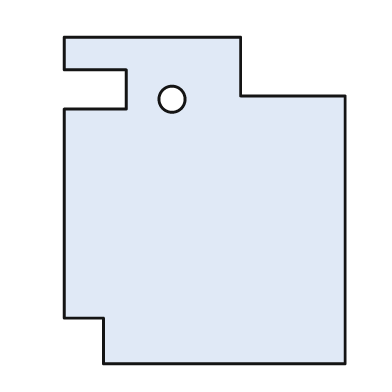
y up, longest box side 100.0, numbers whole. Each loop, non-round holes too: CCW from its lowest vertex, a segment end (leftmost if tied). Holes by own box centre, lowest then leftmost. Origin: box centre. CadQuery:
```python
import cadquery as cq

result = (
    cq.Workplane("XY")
    .moveTo(-31.0, -50.0)
    .lineTo(43.0, -50.0)
    .lineTo(43.0, 32.0)
    .lineTo(11.0, 32.0)
    .lineTo(11.0, 50.0)
    .lineTo(-43.0, 50.0)
    .lineTo(-43.0, 40.0)
    .lineTo(-24.0, 40.0)
    .lineTo(-24.0, 28.0)
    .lineTo(-43.0, 28.0)
    .lineTo(-43.0, -36.0)
    .lineTo(-31.0, -36.0)
    .close()
    .moveTo(-10.0, 31.0)
    .circle(4.0)
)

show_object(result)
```